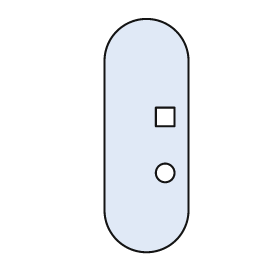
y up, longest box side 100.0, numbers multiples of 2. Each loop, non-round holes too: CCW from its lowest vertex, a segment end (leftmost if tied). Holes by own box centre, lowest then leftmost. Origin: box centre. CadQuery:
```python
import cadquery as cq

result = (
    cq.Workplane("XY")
    .moveTo(-18.0, -32.0)
    .threePointArc((0.0, -50.0), (18.0, -32.0))
    .lineTo(18.0, 32.0)
    .threePointArc((0.0, 50.0), (-18.0, 32.0))
    .close()
    .moveTo(8.0, -16.0)
    .circle(4.0)
    .moveTo(4.0, 4.0)
    .lineTo(12.0, 4.0)
    .lineTo(12.0, 12.0)
    .lineTo(4.0, 12.0)
    .close()
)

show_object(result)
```